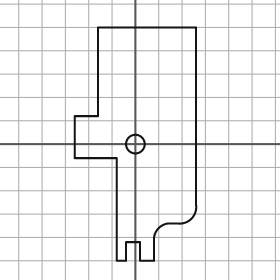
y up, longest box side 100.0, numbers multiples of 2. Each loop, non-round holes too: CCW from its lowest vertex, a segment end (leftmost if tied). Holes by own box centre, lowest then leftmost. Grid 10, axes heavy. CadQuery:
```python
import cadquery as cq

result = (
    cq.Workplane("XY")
    .moveTo(-8.0, -50.0)
    .lineTo(-4.0, -50.0)
    .lineTo(-4.0, -42.0)
    .lineTo(2.0, -42.0)
    .lineTo(2.0, -50.0)
    .lineTo(8.0, -50.0)
    .lineTo(8.0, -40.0)
    .threePointArc((10.0, -36.0), (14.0, -34.0))
    .lineTo(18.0, -34.0)
    .threePointArc((24.0, -32.0), (26.0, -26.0))
    .lineTo(26.0, 50.0)
    .lineTo(-16.0, 50.0)
    .lineTo(-16.0, 12.0)
    .lineTo(-26.0, 12.0)
    .lineTo(-26.0, -6.0)
    .lineTo(-8.0, -6.0)
    .close()
    .moveTo(0.0, 0.0)
    .circle(4.0)
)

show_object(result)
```